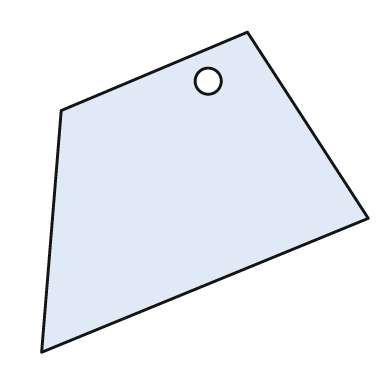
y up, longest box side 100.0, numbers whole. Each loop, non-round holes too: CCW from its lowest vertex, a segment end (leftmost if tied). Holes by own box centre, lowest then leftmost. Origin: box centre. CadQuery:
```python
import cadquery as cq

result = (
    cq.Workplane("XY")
    .moveTo(-50.0, -49.0)
    .lineTo(50.0, -8.0)
    .lineTo(13.0, 49.0)
    .lineTo(-44.0, 25.0)
    .close()
    .moveTo(1.0, 34.0)
    .circle(4.0)
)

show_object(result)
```